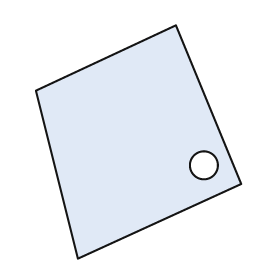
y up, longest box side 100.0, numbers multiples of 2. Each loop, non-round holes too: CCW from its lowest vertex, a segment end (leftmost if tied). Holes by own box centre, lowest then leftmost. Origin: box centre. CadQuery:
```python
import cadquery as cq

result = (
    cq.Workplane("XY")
    .moveTo(-26.0, -50.0)
    .lineTo(44.0, -18.0)
    .lineTo(16.0, 50.0)
    .lineTo(-44.0, 22.0)
    .close()
    .moveTo(28.0, -10.0)
    .circle(6.0)
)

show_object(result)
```